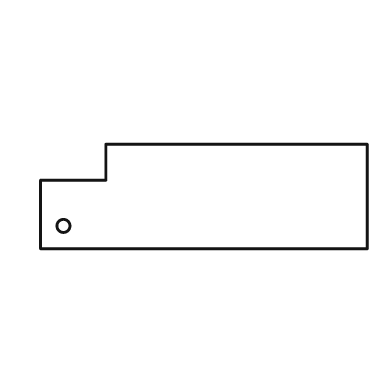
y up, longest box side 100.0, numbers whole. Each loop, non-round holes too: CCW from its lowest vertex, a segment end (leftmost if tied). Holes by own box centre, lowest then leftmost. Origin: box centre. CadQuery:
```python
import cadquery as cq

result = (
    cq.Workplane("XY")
    .moveTo(-50.0, -16.0)
    .lineTo(50.0, -16.0)
    .lineTo(50.0, 16.0)
    .lineTo(-30.0, 16.0)
    .lineTo(-30.0, 5.0)
    .lineTo(-50.0, 5.0)
    .close()
    .moveTo(-43.0, -9.0)
    .circle(2.0)
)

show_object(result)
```